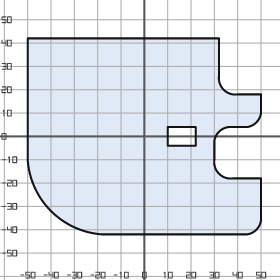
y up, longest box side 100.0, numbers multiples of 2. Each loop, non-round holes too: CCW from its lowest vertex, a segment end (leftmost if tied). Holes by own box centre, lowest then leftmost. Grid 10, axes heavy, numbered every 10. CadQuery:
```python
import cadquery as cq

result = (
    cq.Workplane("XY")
    .moveTo(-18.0, -42.0)
    .lineTo(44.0, -42.0)
    .threePointArc((48.0, -40.0), (50.0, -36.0))
    .lineTo(50.0, -18.0)
    .lineTo(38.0, -18.0)
    .threePointArc((32.0, -16.0), (30.0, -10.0))
    .lineTo(30.0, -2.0)
    .threePointArc((32.0, 2.0), (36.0, 4.0))
    .lineTo(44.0, 4.0)
    .threePointArc((48.0, 6.0), (50.0, 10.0))
    .lineTo(50.0, 18.0)
    .lineTo(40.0, 18.0)
    .threePointArc((34.0, 20.0), (32.0, 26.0))
    .lineTo(32.0, 42.0)
    .lineTo(-50.0, 42.0)
    .lineTo(-50.0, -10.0)
    .threePointArc((-40.0, -32.0), (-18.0, -42.0))
    .close()
    .moveTo(10.0, -4.0)
    .lineTo(22.0, -4.0)
    .lineTo(22.0, 4.0)
    .lineTo(10.0, 4.0)
    .close()
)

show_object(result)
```